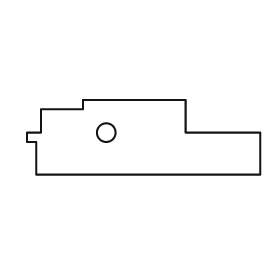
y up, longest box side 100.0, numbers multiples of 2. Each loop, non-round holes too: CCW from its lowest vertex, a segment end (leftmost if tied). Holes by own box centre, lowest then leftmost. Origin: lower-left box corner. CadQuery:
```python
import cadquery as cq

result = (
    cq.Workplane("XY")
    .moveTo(4.0, 0.0)
    .lineTo(100.0, 0.0)
    .lineTo(100.0, 18.0)
    .lineTo(68.0, 18.0)
    .lineTo(68.0, 32.0)
    .lineTo(24.0, 32.0)
    .lineTo(24.0, 28.0)
    .lineTo(6.0, 28.0)
    .lineTo(6.0, 18.0)
    .lineTo(0.0, 18.0)
    .lineTo(0.0, 14.0)
    .lineTo(4.0, 14.0)
    .close()
    .moveTo(34.0, 18.0)
    .circle(4.0)
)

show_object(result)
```